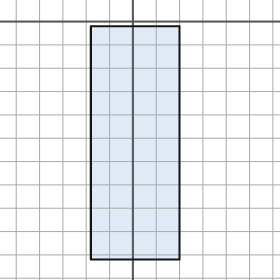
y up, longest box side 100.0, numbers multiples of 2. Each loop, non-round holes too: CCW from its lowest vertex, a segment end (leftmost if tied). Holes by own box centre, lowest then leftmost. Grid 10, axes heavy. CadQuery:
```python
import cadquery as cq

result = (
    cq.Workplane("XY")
    .moveTo(-18.0, -102.0)
    .lineTo(20.0, -102.0)
    .lineTo(20.0, -2.0)
    .lineTo(-18.0, -2.0)
    .close()
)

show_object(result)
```